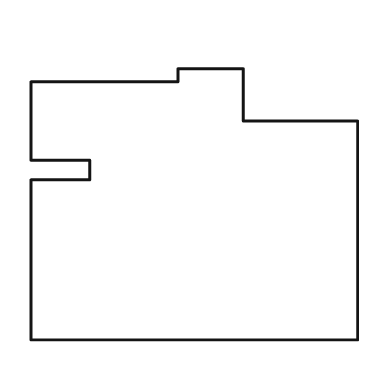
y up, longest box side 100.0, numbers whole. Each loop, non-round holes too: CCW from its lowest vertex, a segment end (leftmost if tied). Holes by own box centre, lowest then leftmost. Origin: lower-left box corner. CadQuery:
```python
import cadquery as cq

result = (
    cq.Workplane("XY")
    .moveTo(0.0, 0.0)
    .lineTo(100.0, 0.0)
    .lineTo(100.0, 67.0)
    .lineTo(65.0, 67.0)
    .lineTo(65.0, 83.0)
    .lineTo(45.0, 83.0)
    .lineTo(45.0, 79.0)
    .lineTo(0.0, 79.0)
    .lineTo(0.0, 55.0)
    .lineTo(18.0, 55.0)
    .lineTo(18.0, 49.0)
    .lineTo(0.0, 49.0)
    .close()
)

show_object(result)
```